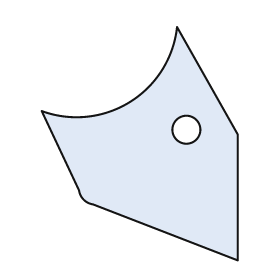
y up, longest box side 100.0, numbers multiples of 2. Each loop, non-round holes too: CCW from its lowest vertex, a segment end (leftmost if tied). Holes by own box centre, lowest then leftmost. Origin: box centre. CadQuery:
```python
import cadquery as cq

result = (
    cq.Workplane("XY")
    .moveTo(42.0, -50.0)
    .lineTo(42.0, 4.0)
    .lineTo(16.0, 50.0)
    .threePointArc((-4.0, 18.0), (-42.0, 14.0))
    .lineTo(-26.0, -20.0)
    .threePointArc((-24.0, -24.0), (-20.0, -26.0))
    .close()
    .moveTo(20.0, 6.0)
    .circle(6.0)
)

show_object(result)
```